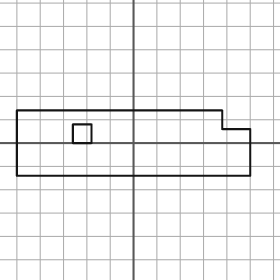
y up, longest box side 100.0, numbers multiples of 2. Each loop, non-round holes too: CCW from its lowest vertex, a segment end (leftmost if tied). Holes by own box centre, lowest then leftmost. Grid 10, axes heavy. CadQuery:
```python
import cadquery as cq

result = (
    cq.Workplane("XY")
    .moveTo(-50.0, -14.0)
    .lineTo(50.0, -14.0)
    .lineTo(50.0, 6.0)
    .lineTo(38.0, 6.0)
    .lineTo(38.0, 14.0)
    .lineTo(-50.0, 14.0)
    .close()
    .moveTo(-26.0, 0.0)
    .lineTo(-18.0, 0.0)
    .lineTo(-18.0, 8.0)
    .lineTo(-26.0, 8.0)
    .close()
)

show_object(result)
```